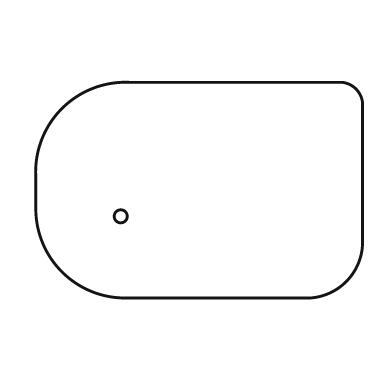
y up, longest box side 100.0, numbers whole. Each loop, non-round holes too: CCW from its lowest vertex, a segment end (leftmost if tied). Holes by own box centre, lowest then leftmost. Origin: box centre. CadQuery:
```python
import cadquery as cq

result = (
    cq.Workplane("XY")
    .moveTo(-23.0, -33.0)
    .lineTo(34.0, -33.0)
    .threePointArc((45.0, -28.0), (50.0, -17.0))
    .lineTo(50.0, 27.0)
    .threePointArc((48.0, 31.0), (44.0, 33.0))
    .lineTo(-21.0, 33.0)
    .threePointArc((-42.0, 25.0), (-50.0, 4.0))
    .lineTo(-50.0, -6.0)
    .threePointArc((-42.0, -25.0), (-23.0, -33.0))
    .close()
    .moveTo(-24.0, -8.0)
    .circle(2.0)
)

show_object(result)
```